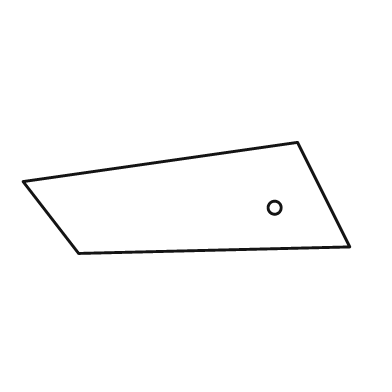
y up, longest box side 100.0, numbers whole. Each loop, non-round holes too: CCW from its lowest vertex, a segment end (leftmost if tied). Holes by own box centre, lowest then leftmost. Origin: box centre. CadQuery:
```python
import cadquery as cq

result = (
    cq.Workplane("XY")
    .moveTo(-33.0, -17.0)
    .lineTo(50.0, -15.0)
    .lineTo(34.0, 17.0)
    .lineTo(-50.0, 5.0)
    .close()
    .moveTo(27.0, -3.0)
    .circle(2.0)
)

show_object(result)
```